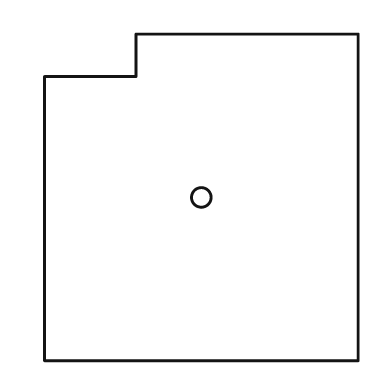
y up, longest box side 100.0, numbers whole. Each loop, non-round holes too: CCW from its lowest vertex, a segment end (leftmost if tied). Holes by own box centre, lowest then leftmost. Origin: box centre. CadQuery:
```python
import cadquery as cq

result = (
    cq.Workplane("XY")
    .moveTo(-48.0, -50.0)
    .lineTo(48.0, -50.0)
    .lineTo(48.0, 50.0)
    .lineTo(-20.0, 50.0)
    .lineTo(-20.0, 37.0)
    .lineTo(-48.0, 37.0)
    .close()
    .moveTo(0.0, 0.0)
    .circle(3.0)
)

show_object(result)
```